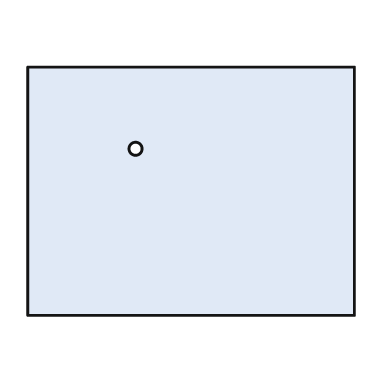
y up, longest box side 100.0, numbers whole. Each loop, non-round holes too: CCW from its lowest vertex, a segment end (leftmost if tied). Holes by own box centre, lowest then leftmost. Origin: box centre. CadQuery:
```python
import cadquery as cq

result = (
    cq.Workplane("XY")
    .moveTo(-50.0, -38.0)
    .lineTo(50.0, -38.0)
    .lineTo(50.0, 38.0)
    .lineTo(-50.0, 38.0)
    .close()
    .moveTo(-17.0, 13.0)
    .circle(2.0)
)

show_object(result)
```